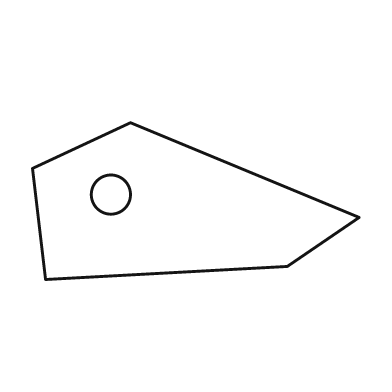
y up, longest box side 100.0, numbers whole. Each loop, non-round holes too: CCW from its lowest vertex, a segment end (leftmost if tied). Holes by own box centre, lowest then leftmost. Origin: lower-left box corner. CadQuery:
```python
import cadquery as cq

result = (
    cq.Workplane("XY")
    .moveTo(4.0, 0.0)
    .lineTo(78.0, 4.0)
    .lineTo(100.0, 19.0)
    .lineTo(30.0, 48.0)
    .lineTo(0.0, 34.0)
    .close()
    .moveTo(24.0, 26.0)
    .circle(6.0)
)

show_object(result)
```